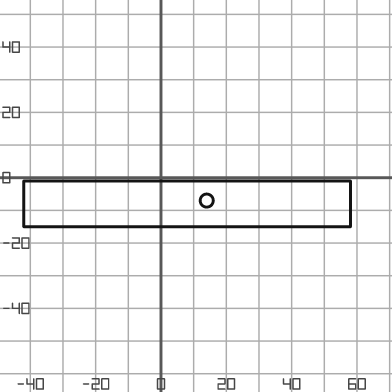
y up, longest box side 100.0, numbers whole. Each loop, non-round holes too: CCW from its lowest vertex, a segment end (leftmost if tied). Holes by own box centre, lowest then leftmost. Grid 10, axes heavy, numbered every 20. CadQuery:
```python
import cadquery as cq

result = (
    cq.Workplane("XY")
    .moveTo(-42.0, -15.0)
    .lineTo(58.0, -15.0)
    .lineTo(58.0, -1.0)
    .lineTo(-42.0, -1.0)
    .close()
    .moveTo(14.0, -7.0)
    .circle(2.0)
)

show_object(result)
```